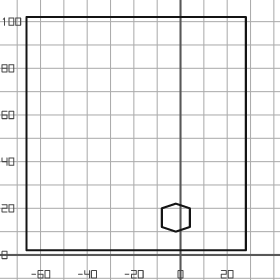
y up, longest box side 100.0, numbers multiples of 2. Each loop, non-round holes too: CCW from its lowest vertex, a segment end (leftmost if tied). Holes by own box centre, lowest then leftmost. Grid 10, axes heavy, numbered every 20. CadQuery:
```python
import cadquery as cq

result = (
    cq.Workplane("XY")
    .moveTo(-66.0, 2.0)
    .lineTo(28.0, 2.0)
    .lineTo(28.0, 102.0)
    .lineTo(-66.0, 102.0)
    .close()
    .moveTo(-2.0, 10.0)
    .lineTo(4.0, 12.0)
    .lineTo(4.0, 20.0)
    .lineTo(-2.0, 22.0)
    .lineTo(-8.0, 20.0)
    .lineTo(-8.0, 12.0)
    .close()
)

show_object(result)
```